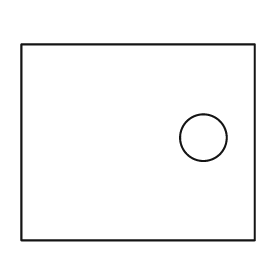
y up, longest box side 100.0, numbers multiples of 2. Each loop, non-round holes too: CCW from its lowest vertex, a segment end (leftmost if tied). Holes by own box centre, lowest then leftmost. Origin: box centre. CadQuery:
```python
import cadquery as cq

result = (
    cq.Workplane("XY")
    .moveTo(-50.0, -42.0)
    .lineTo(50.0, -42.0)
    .lineTo(50.0, 42.0)
    .lineTo(-50.0, 42.0)
    .close()
    .moveTo(28.0, 2.0)
    .circle(10.0)
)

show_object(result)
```